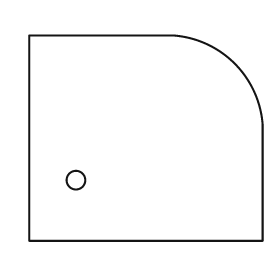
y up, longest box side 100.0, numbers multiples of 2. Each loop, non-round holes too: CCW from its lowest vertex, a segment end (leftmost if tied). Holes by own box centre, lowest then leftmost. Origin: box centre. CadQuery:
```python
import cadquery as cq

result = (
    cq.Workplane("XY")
    .moveTo(-50.0, -44.0)
    .lineTo(50.0, -44.0)
    .lineTo(50.0, 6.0)
    .threePointArc((38.0, 32.0), (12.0, 44.0))
    .lineTo(-50.0, 44.0)
    .close()
    .moveTo(-30.0, -18.0)
    .circle(4.0)
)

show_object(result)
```